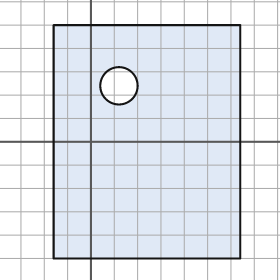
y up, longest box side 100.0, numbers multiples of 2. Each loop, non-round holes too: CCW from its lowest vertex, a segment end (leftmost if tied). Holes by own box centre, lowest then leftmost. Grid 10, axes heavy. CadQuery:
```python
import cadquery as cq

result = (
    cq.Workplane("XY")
    .moveTo(-16.0, -50.0)
    .lineTo(64.0, -50.0)
    .lineTo(64.0, 50.0)
    .lineTo(-16.0, 50.0)
    .close()
    .moveTo(12.0, 24.0)
    .circle(8.0)
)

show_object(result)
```